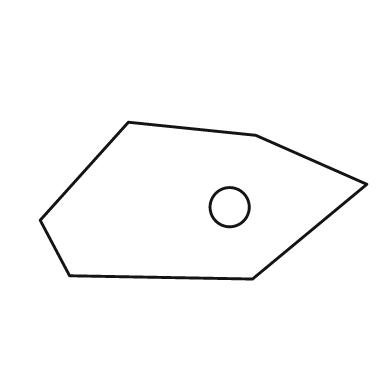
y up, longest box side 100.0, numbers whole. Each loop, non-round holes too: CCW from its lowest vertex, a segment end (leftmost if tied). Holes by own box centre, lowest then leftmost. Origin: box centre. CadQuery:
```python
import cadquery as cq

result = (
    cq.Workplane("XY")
    .moveTo(15.0, -24.0)
    .lineTo(50.0, 5.0)
    .lineTo(16.0, 20.0)
    .lineTo(-23.0, 24.0)
    .lineTo(-50.0, -6.0)
    .lineTo(-41.0, -23.0)
    .close()
    .moveTo(8.0, -2.0)
    .circle(6.0)
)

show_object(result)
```